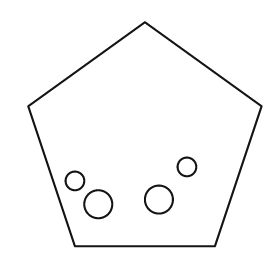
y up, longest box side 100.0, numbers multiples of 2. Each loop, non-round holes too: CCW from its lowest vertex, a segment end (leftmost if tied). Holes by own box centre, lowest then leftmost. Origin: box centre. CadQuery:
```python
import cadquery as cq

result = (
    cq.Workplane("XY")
    .moveTo(-30.0, -48.0)
    .lineTo(30.0, -48.0)
    .lineTo(50.0, 12.0)
    .lineTo(0.0, 48.0)
    .lineTo(-50.0, 12.0)
    .close()
    .moveTo(-20.0, -30.0)
    .circle(6.0)
    .moveTo(6.0, -28.0)
    .circle(6.0)
    .moveTo(-30.0, -20.0)
    .circle(4.0)
    .moveTo(18.0, -14.0)
    .circle(4.0)
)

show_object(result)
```